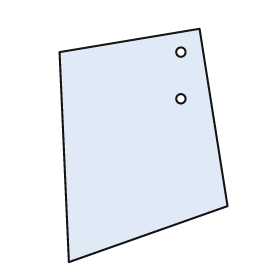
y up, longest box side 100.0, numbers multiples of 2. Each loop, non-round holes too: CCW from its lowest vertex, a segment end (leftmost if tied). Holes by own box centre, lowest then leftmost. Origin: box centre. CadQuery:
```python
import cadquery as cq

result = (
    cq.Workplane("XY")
    .moveTo(-32.0, -50.0)
    .lineTo(36.0, -26.0)
    .lineTo(24.0, 50.0)
    .lineTo(-36.0, 40.0)
    .close()
    .moveTo(16.0, 20.0)
    .circle(2.0)
    .moveTo(16.0, 40.0)
    .circle(2.0)
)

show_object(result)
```